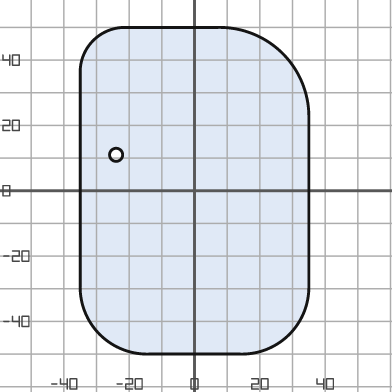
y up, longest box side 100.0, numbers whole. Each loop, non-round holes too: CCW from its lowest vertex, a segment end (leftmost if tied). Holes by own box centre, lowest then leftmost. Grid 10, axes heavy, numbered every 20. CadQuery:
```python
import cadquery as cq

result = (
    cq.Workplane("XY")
    .moveTo(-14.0, -50.0)
    .lineTo(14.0, -50.0)
    .threePointArc((29.0, -44.0), (35.0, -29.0))
    .lineTo(35.0, 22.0)
    .threePointArc((27.0, 42.0), (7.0, 50.0))
    .lineTo(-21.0, 50.0)
    .threePointArc((-31.0, 46.0), (-35.0, 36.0))
    .lineTo(-35.0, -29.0)
    .threePointArc((-29.0, -44.0), (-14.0, -50.0))
    .close()
    .moveTo(-24.0, 11.0)
    .circle(2.0)
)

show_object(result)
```